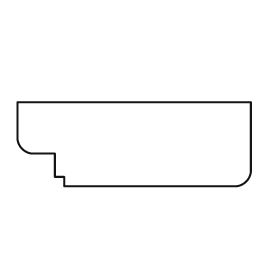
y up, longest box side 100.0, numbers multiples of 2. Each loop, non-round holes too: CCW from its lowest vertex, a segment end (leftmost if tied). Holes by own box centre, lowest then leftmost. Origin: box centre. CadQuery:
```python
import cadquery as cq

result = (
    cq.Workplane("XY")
    .moveTo(-30.0, -18.0)
    .lineTo(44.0, -18.0)
    .threePointArc((48.0, -16.0), (50.0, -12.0))
    .lineTo(50.0, 18.0)
    .lineTo(-50.0, 18.0)
    .lineTo(-50.0, 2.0)
    .threePointArc((-48.0, -2.0), (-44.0, -4.0))
    .lineTo(-34.0, -4.0)
    .lineTo(-34.0, -14.0)
    .lineTo(-30.0, -14.0)
    .close()
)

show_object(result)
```